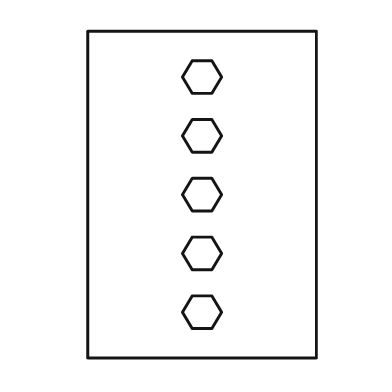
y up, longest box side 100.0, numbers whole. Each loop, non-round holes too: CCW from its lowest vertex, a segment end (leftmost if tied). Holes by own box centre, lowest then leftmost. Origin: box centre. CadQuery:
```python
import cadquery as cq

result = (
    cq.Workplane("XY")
    .moveTo(-35.0, -50.0)
    .lineTo(35.0, -50.0)
    .lineTo(35.0, 50.0)
    .lineTo(-35.0, 50.0)
    .close()
    .moveTo(-3.0, -41.0)
    .lineTo(3.0, -41.0)
    .lineTo(6.0, -36.0)
    .lineTo(3.0, -31.0)
    .lineTo(-3.0, -31.0)
    .lineTo(-6.0, -36.0)
    .close()
    .moveTo(-3.0, -23.0)
    .lineTo(3.0, -23.0)
    .lineTo(6.0, -18.0)
    .lineTo(3.0, -13.0)
    .lineTo(-3.0, -13.0)
    .lineTo(-6.0, -18.0)
    .close()
    .moveTo(-3.0, -5.0)
    .lineTo(3.0, -5.0)
    .lineTo(6.0, 0.0)
    .lineTo(3.0, 5.0)
    .lineTo(-3.0, 5.0)
    .lineTo(-6.0, 0.0)
    .close()
    .moveTo(-3.0, 13.0)
    .lineTo(3.0, 13.0)
    .lineTo(6.0, 18.0)
    .lineTo(3.0, 23.0)
    .lineTo(-3.0, 23.0)
    .lineTo(-6.0, 18.0)
    .close()
    .moveTo(-3.0, 31.0)
    .lineTo(3.0, 31.0)
    .lineTo(6.0, 36.0)
    .lineTo(3.0, 41.0)
    .lineTo(-3.0, 41.0)
    .lineTo(-6.0, 36.0)
    .close()
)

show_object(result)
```